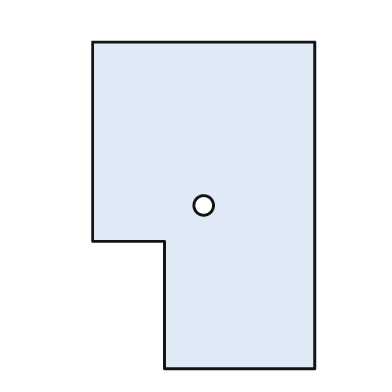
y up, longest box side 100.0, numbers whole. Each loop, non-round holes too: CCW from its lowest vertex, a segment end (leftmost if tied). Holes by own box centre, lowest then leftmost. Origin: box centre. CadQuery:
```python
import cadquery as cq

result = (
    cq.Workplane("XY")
    .moveTo(-12.0, -50.0)
    .lineTo(34.0, -50.0)
    .lineTo(34.0, 50.0)
    .lineTo(-34.0, 50.0)
    .lineTo(-34.0, -11.0)
    .lineTo(-12.0, -11.0)
    .close()
    .moveTo(0.0, 0.0)
    .circle(3.0)
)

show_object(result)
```